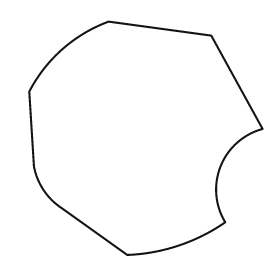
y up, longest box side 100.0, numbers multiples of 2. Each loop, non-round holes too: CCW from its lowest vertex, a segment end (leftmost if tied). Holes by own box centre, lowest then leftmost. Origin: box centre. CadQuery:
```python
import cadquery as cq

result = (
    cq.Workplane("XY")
    .moveTo(-8.0, -50.0)
    .threePointArc((14.0, -46.0), (34.0, -36.0))
    .threePointArc((32.0, -12.0), (50.0, 4.0))
    .lineTo(28.0, 44.0)
    .lineTo(-16.0, 50.0)
    .threePointArc((-36.0, 38.0), (-50.0, 20.0))
    .lineTo(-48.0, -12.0)
    .threePointArc((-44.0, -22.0), (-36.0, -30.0))
    .close()
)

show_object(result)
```